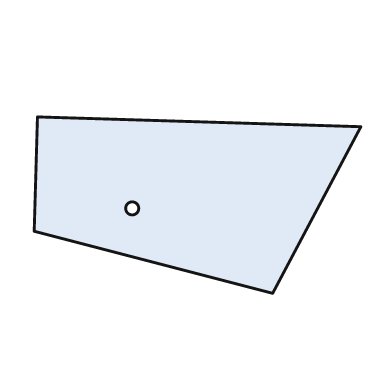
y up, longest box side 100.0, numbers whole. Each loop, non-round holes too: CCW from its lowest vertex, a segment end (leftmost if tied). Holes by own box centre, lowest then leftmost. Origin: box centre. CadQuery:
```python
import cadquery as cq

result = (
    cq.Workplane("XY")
    .moveTo(23.0, -27.0)
    .lineTo(50.0, 24.0)
    .lineTo(-49.0, 27.0)
    .lineTo(-50.0, -8.0)
    .close()
    .moveTo(-20.0, -1.0)
    .circle(2.0)
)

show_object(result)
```